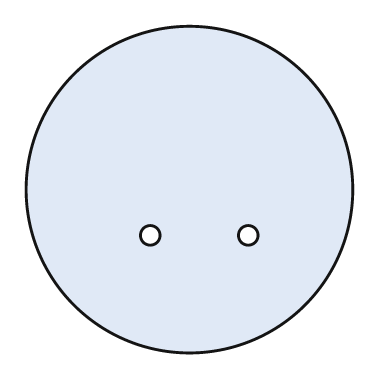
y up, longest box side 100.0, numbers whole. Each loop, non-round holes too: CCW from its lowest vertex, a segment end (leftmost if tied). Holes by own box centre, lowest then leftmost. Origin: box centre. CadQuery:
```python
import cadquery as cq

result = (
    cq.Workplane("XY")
    .moveTo(0.0, 0.0)
    .circle(50.0)
    .moveTo(-12.0, -14.0)
    .circle(3.0)
    .moveTo(18.0, -14.0)
    .circle(3.0)
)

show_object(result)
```